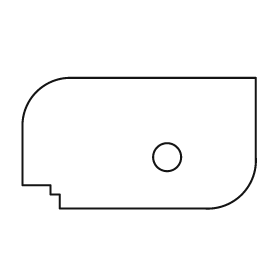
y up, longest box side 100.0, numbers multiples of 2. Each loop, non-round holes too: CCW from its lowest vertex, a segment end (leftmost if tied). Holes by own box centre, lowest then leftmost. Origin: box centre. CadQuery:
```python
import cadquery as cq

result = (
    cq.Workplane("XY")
    .moveTo(-34.0, -28.0)
    .lineTo(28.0, -28.0)
    .threePointArc((44.0, -22.0), (50.0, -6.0))
    .lineTo(50.0, 28.0)
    .lineTo(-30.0, 28.0)
    .threePointArc((-44.0, 22.0), (-50.0, 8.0))
    .lineTo(-50.0, -18.0)
    .lineTo(-38.0, -18.0)
    .lineTo(-38.0, -22.0)
    .lineTo(-34.0, -22.0)
    .close()
    .moveTo(12.0, -6.0)
    .circle(6.0)
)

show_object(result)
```